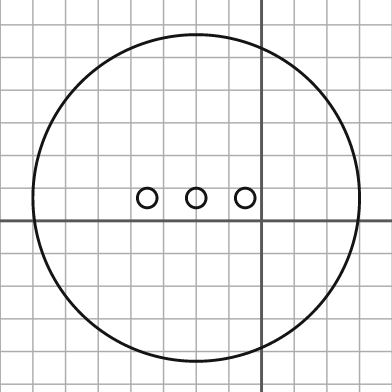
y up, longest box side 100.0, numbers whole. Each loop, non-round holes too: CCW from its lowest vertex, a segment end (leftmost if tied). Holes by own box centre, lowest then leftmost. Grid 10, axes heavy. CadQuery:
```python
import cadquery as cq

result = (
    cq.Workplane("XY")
    .moveTo(-20.0, 7.0)
    .circle(50.0)
    .moveTo(-35.0, 7.0)
    .circle(3.0)
    .moveTo(-20.0, 7.0)
    .circle(3.0)
    .moveTo(-5.0, 7.0)
    .circle(3.0)
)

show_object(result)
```